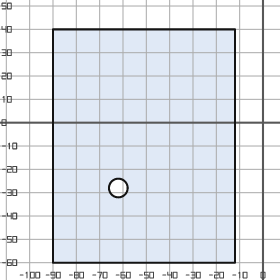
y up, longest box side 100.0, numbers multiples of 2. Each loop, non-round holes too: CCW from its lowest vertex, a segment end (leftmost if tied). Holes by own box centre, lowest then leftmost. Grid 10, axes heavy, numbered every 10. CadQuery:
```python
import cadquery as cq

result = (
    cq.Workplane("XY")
    .moveTo(-90.0, -60.0)
    .lineTo(-12.0, -60.0)
    .lineTo(-12.0, 40.0)
    .lineTo(-90.0, 40.0)
    .close()
    .moveTo(-62.0, -28.0)
    .circle(4.0)
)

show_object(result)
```